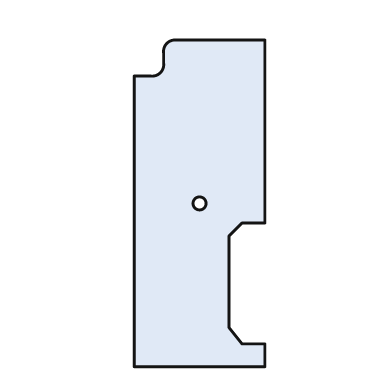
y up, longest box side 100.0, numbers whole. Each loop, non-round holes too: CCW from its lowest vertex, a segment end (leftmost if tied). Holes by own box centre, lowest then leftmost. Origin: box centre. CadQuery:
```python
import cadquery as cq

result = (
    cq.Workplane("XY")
    .moveTo(-20.0, -50.0)
    .lineTo(20.0, -50.0)
    .lineTo(20.0, -43.0)
    .lineTo(13.0, -43.0)
    .lineTo(9.0, -38.0)
    .lineTo(9.0, -10.0)
    .lineTo(13.0, -6.0)
    .lineTo(20.0, -6.0)
    .lineTo(20.0, 50.0)
    .lineTo(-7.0, 50.0)
    .threePointArc((-10.0, 49.0), (-11.0, 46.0))
    .lineTo(-11.0, 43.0)
    .threePointArc((-12.0, 40.0), (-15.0, 39.0))
    .lineTo(-20.0, 39.0)
    .close()
    .moveTo(0.0, 0.0)
    .circle(2.0)
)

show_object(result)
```